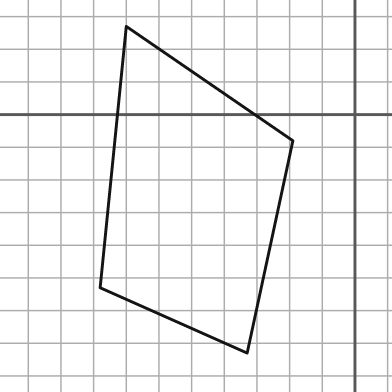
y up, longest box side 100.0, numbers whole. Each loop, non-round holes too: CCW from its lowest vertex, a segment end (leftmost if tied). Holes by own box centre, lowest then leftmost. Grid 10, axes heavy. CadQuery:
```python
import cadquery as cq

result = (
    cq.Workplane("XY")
    .moveTo(-33.0, -73.0)
    .lineTo(-19.0, -8.0)
    .lineTo(-70.0, 27.0)
    .lineTo(-78.0, -53.0)
    .close()
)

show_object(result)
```